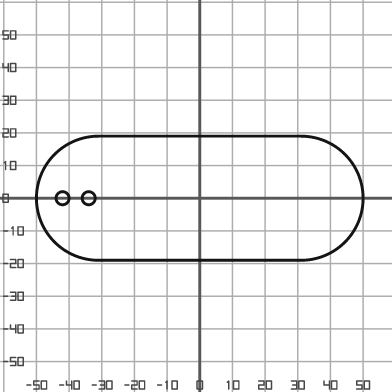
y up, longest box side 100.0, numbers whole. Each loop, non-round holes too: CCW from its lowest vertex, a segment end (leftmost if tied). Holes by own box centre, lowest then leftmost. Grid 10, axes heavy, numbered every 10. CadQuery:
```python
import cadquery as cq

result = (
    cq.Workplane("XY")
    .moveTo(-31.0, -19.0)
    .lineTo(31.0, -19.0)
    .threePointArc((50.0, 0.0), (31.0, 19.0))
    .lineTo(-31.0, 19.0)
    .threePointArc((-50.0, 0.0), (-31.0, -19.0))
    .close()
    .moveTo(-42.0, 0.0)
    .circle(2.0)
    .moveTo(-34.0, 0.0)
    .circle(2.0)
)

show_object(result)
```